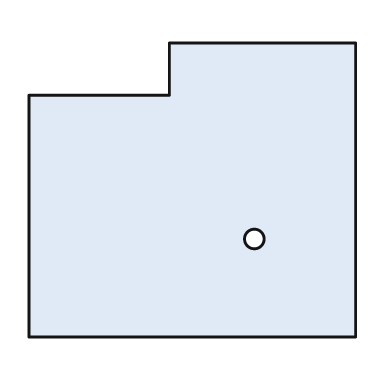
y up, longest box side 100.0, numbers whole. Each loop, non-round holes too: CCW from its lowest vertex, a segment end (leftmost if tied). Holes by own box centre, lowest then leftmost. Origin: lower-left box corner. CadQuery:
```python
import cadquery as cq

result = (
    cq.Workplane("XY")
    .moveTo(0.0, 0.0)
    .lineTo(100.0, 0.0)
    .lineTo(100.0, 90.0)
    .lineTo(43.0, 90.0)
    .lineTo(43.0, 74.0)
    .lineTo(0.0, 74.0)
    .close()
    .moveTo(69.0, 30.0)
    .circle(3.0)
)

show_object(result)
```